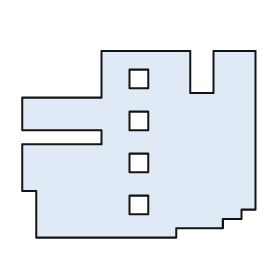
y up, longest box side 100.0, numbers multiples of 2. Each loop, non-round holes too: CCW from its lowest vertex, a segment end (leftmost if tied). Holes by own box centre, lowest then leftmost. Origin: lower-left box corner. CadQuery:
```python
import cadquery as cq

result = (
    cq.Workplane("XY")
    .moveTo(6.0, 0.0)
    .lineTo(66.0, 0.0)
    .lineTo(66.0, 4.0)
    .lineTo(86.0, 4.0)
    .lineTo(86.0, 8.0)
    .lineTo(94.0, 8.0)
    .lineTo(94.0, 12.0)
    .lineTo(100.0, 12.0)
    .lineTo(100.0, 80.0)
    .lineTo(82.0, 80.0)
    .lineTo(82.0, 62.0)
    .lineTo(72.0, 62.0)
    .lineTo(72.0, 80.0)
    .lineTo(34.0, 80.0)
    .lineTo(34.0, 60.0)
    .lineTo(0.0, 60.0)
    .lineTo(0.0, 46.0)
    .lineTo(34.0, 46.0)
    .lineTo(34.0, 40.0)
    .lineTo(0.0, 40.0)
    .lineTo(0.0, 20.0)
    .lineTo(6.0, 20.0)
    .close()
    .moveTo(46.0, 10.0)
    .lineTo(54.0, 10.0)
    .lineTo(54.0, 18.0)
    .lineTo(46.0, 18.0)
    .close()
    .moveTo(46.0, 28.0)
    .lineTo(54.0, 28.0)
    .lineTo(54.0, 36.0)
    .lineTo(46.0, 36.0)
    .close()
    .moveTo(46.0, 46.0)
    .lineTo(54.0, 46.0)
    .lineTo(54.0, 54.0)
    .lineTo(46.0, 54.0)
    .close()
    .moveTo(46.0, 64.0)
    .lineTo(54.0, 64.0)
    .lineTo(54.0, 72.0)
    .lineTo(46.0, 72.0)
    .close()
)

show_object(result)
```